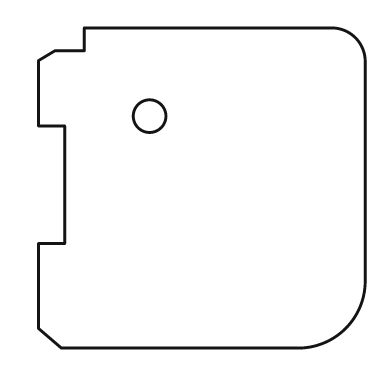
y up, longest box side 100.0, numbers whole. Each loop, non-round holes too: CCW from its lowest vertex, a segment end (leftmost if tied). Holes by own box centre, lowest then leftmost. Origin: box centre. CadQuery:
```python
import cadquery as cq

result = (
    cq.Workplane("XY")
    .moveTo(-43.0, -49.0)
    .lineTo(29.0, -49.0)
    .threePointArc((44.0, -43.0), (50.0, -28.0))
    .lineTo(50.0, 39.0)
    .threePointArc((47.0, 46.0), (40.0, 49.0))
    .lineTo(-36.0, 49.0)
    .lineTo(-36.0, 42.0)
    .lineTo(-45.0, 42.0)
    .lineTo(-50.0, 39.0)
    .lineTo(-50.0, 19.0)
    .lineTo(-42.0, 19.0)
    .lineTo(-42.0, -17.0)
    .lineTo(-50.0, -17.0)
    .lineTo(-50.0, -43.0)
    .close()
    .moveTo(-16.0, 22.0)
    .circle(5.0)
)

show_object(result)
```